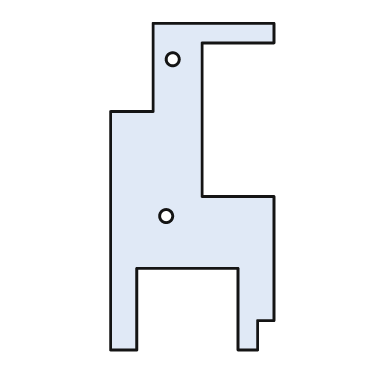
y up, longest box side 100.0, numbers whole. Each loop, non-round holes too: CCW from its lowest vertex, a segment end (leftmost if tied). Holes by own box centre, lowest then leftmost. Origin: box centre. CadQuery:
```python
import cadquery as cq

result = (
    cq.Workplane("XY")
    .moveTo(-25.0, -50.0)
    .lineTo(-17.0, -50.0)
    .lineTo(-17.0, -25.0)
    .lineTo(14.0, -25.0)
    .lineTo(14.0, -50.0)
    .lineTo(20.0, -50.0)
    .lineTo(20.0, -41.0)
    .lineTo(25.0, -41.0)
    .lineTo(25.0, -3.0)
    .lineTo(3.0, -3.0)
    .lineTo(3.0, 44.0)
    .lineTo(25.0, 44.0)
    .lineTo(25.0, 50.0)
    .lineTo(-12.0, 50.0)
    .lineTo(-12.0, 23.0)
    .lineTo(-25.0, 23.0)
    .close()
    .moveTo(-8.0, -9.0)
    .circle(2.0)
    .moveTo(-6.0, 39.0)
    .circle(2.0)
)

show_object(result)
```